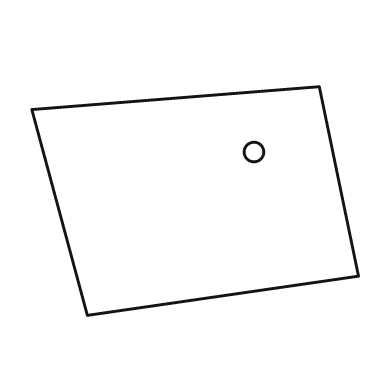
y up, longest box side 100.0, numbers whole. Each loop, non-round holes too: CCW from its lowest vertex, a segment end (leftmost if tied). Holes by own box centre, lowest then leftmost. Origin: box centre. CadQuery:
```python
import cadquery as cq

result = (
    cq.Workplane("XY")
    .moveTo(-33.0, -35.0)
    .lineTo(50.0, -23.0)
    .lineTo(38.0, 35.0)
    .lineTo(-50.0, 28.0)
    .close()
    .moveTo(18.0, 15.0)
    .circle(3.0)
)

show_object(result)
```